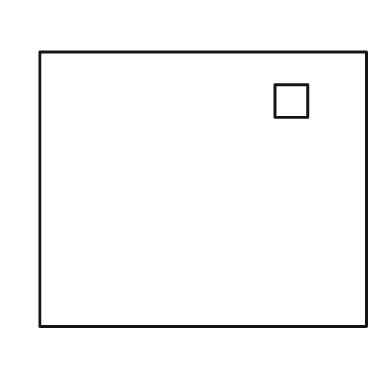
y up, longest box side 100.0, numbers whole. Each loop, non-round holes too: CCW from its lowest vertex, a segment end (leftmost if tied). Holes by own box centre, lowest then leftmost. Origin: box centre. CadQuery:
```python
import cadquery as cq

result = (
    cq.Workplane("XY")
    .moveTo(-50.0, -42.0)
    .lineTo(50.0, -42.0)
    .lineTo(50.0, 42.0)
    .lineTo(-50.0, 42.0)
    .close()
    .moveTo(22.0, 22.0)
    .lineTo(32.0, 22.0)
    .lineTo(32.0, 32.0)
    .lineTo(22.0, 32.0)
    .close()
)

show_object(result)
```